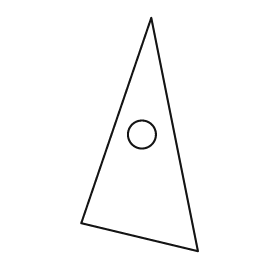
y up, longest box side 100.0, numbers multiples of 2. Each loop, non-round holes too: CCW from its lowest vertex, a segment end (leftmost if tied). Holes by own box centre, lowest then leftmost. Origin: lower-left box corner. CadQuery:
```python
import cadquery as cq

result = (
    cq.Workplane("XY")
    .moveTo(50.0, 0.0)
    .lineTo(30.0, 100.0)
    .lineTo(0.0, 12.0)
    .close()
    .moveTo(26.0, 50.0)
    .circle(6.0)
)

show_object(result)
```